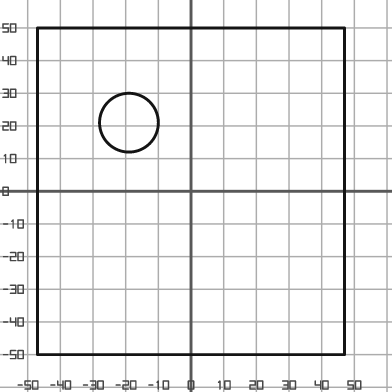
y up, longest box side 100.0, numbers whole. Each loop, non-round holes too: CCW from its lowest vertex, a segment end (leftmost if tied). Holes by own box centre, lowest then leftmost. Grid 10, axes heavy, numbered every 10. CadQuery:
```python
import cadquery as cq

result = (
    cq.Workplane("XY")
    .moveTo(-47.0, -50.0)
    .lineTo(47.0, -50.0)
    .lineTo(47.0, 50.0)
    .lineTo(-47.0, 50.0)
    .close()
    .moveTo(-19.0, 21.0)
    .circle(9.0)
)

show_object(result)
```